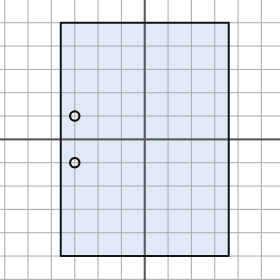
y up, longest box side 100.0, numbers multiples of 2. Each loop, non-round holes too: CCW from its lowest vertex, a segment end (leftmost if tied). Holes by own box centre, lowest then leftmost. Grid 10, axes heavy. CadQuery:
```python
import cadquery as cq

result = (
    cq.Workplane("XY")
    .moveTo(-36.0, -50.0)
    .lineTo(36.0, -50.0)
    .lineTo(36.0, 50.0)
    .lineTo(-36.0, 50.0)
    .close()
    .moveTo(-30.0, -10.0)
    .circle(2.0)
    .moveTo(-30.0, 10.0)
    .circle(2.0)
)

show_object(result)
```